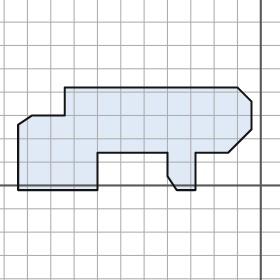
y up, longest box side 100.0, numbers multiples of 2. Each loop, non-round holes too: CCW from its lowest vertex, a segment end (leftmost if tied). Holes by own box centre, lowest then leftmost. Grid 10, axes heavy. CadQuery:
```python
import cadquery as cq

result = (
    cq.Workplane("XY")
    .moveTo(-104.0, -2.0)
    .lineTo(-70.0, -2.0)
    .lineTo(-70.0, 14.0)
    .lineTo(-40.0, 14.0)
    .lineTo(-40.0, 4.0)
    .lineTo(-36.0, -2.0)
    .lineTo(-28.0, -2.0)
    .lineTo(-28.0, 14.0)
    .lineTo(-14.0, 14.0)
    .lineTo(-4.0, 24.0)
    .lineTo(-4.0, 36.0)
    .lineTo(-10.0, 42.0)
    .lineTo(-84.0, 42.0)
    .lineTo(-84.0, 30.0)
    .lineTo(-98.0, 30.0)
    .lineTo(-104.0, 26.0)
    .close()
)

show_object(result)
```